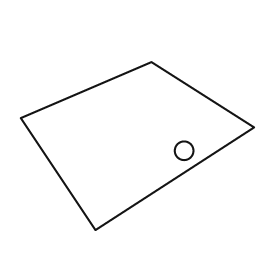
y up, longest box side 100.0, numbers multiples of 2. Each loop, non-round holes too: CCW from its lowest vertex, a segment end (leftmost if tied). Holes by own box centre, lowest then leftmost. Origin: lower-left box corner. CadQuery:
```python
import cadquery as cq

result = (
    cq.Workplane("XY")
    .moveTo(32.0, 0.0)
    .lineTo(100.0, 44.0)
    .lineTo(56.0, 72.0)
    .lineTo(0.0, 48.0)
    .close()
    .moveTo(70.0, 34.0)
    .circle(4.0)
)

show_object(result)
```